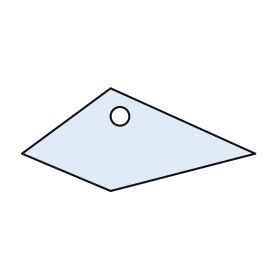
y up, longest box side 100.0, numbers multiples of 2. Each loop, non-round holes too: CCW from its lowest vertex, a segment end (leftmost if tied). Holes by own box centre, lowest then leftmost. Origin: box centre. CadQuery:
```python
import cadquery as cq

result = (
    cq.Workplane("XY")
    .moveTo(-12.0, -22.0)
    .lineTo(50.0, -6.0)
    .lineTo(-12.0, 22.0)
    .lineTo(-50.0, -6.0)
    .close()
    .moveTo(-8.0, 10.0)
    .circle(4.0)
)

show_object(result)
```